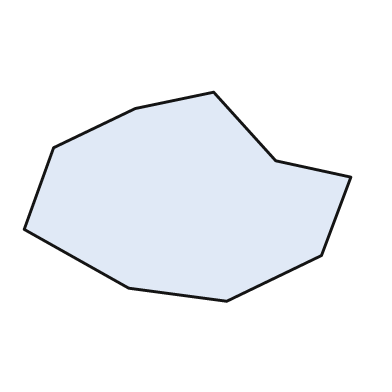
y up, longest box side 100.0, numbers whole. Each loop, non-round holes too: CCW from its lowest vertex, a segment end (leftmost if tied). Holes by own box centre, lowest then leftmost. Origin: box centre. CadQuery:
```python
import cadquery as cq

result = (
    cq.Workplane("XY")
    .moveTo(12.0, -32.0)
    .lineTo(41.0, -18.0)
    .lineTo(50.0, 6.0)
    .lineTo(27.0, 11.0)
    .lineTo(8.0, 32.0)
    .lineTo(-16.0, 27.0)
    .lineTo(-41.0, 15.0)
    .lineTo(-50.0, -10.0)
    .lineTo(-18.0, -28.0)
    .close()
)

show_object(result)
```